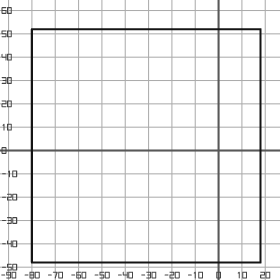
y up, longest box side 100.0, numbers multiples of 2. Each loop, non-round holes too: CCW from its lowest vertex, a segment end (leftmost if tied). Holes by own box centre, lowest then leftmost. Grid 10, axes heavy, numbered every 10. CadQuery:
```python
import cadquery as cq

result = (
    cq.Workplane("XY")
    .moveTo(-80.0, -48.0)
    .lineTo(18.0, -48.0)
    .lineTo(18.0, 52.0)
    .lineTo(-80.0, 52.0)
    .close()
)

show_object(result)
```